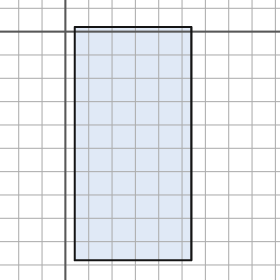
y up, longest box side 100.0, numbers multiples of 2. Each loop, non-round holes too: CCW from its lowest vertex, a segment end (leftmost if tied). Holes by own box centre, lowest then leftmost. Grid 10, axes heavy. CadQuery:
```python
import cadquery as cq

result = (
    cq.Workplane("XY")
    .moveTo(4.0, -98.0)
    .lineTo(54.0, -98.0)
    .lineTo(54.0, 2.0)
    .lineTo(4.0, 2.0)
    .close()
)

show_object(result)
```